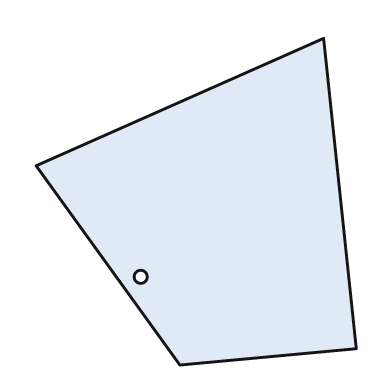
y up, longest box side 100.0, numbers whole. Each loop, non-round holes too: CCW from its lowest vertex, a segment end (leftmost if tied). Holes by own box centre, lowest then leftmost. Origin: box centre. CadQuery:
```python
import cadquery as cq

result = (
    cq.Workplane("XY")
    .moveTo(-5.0, -50.0)
    .lineTo(49.0, -45.0)
    .lineTo(39.0, 50.0)
    .lineTo(-49.0, 11.0)
    .close()
    .moveTo(-17.0, -23.0)
    .circle(2.0)
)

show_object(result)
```